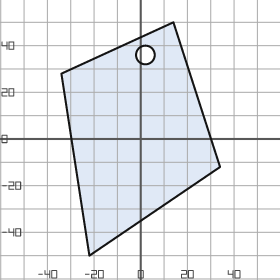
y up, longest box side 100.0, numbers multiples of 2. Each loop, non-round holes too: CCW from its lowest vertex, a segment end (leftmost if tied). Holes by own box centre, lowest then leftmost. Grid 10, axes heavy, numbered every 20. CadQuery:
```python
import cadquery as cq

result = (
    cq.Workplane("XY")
    .moveTo(-22.0, -50.0)
    .lineTo(34.0, -12.0)
    .lineTo(14.0, 50.0)
    .lineTo(-34.0, 28.0)
    .close()
    .moveTo(2.0, 36.0)
    .circle(4.0)
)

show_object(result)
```